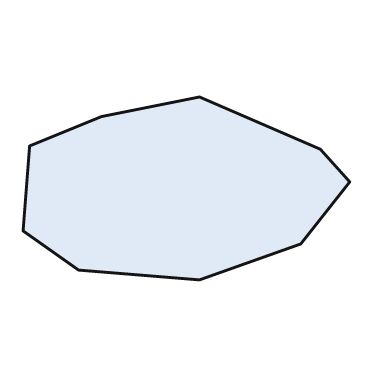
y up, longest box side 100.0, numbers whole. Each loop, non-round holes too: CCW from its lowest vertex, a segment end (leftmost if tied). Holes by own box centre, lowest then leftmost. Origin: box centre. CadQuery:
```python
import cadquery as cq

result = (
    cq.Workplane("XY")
    .moveTo(4.0, -28.0)
    .lineTo(35.0, -17.0)
    .lineTo(50.0, 2.0)
    .lineTo(41.0, 12.0)
    .lineTo(4.0, 28.0)
    .lineTo(-26.0, 22.0)
    .lineTo(-48.0, 13.0)
    .lineTo(-50.0, -13.0)
    .lineTo(-33.0, -25.0)
    .close()
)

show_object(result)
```